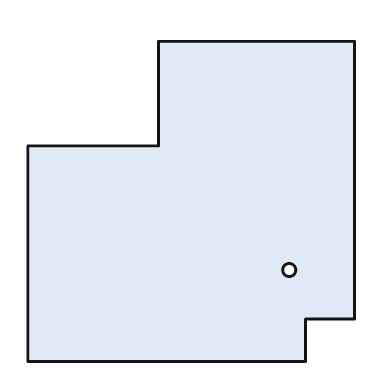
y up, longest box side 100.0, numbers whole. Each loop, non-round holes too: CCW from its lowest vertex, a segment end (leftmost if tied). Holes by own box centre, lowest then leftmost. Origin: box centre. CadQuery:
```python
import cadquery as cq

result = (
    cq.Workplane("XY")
    .moveTo(-50.0, -49.0)
    .lineTo(35.0, -49.0)
    .lineTo(35.0, -36.0)
    .lineTo(50.0, -36.0)
    .lineTo(50.0, 49.0)
    .lineTo(-10.0, 49.0)
    .lineTo(-10.0, 17.0)
    .lineTo(-50.0, 17.0)
    .close()
    .moveTo(30.0, -21.0)
    .circle(2.0)
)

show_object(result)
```